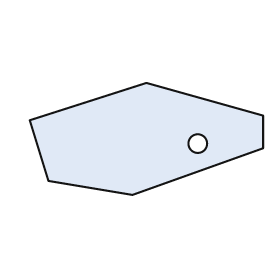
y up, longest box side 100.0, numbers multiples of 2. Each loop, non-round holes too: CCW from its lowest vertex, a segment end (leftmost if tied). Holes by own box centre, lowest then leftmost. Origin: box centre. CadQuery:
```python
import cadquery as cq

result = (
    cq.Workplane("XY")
    .moveTo(-6.0, -24.0)
    .lineTo(50.0, -4.0)
    .lineTo(50.0, 10.0)
    .lineTo(0.0, 24.0)
    .lineTo(-50.0, 8.0)
    .lineTo(-42.0, -18.0)
    .close()
    .moveTo(22.0, -2.0)
    .circle(4.0)
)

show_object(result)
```